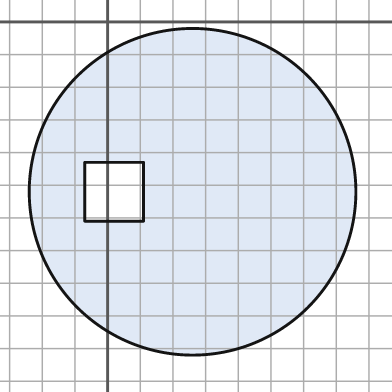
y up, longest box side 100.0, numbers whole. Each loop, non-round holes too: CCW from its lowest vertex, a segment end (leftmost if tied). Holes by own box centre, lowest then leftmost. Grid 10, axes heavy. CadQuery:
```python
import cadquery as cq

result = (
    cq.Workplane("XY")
    .moveTo(26.0, -52.0)
    .circle(50.0)
    .moveTo(-7.0, -61.0)
    .lineTo(11.0, -61.0)
    .lineTo(11.0, -43.0)
    .lineTo(-7.0, -43.0)
    .close()
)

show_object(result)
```